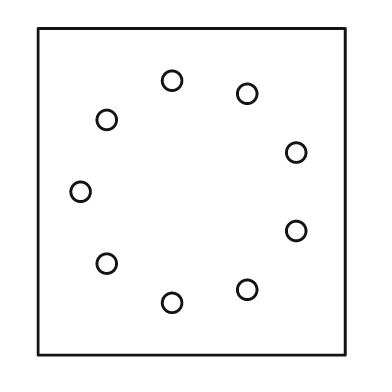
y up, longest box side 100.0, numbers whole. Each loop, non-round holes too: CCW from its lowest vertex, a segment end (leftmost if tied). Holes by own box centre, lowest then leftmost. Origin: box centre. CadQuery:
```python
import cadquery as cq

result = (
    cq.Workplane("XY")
    .moveTo(-47.0, -50.0)
    .lineTo(47.0, -50.0)
    .lineTo(47.0, 50.0)
    .lineTo(-47.0, 50.0)
    .close()
    .moveTo(-6.0, -34.0)
    .circle(3.0)
    .moveTo(17.0, -30.0)
    .circle(3.0)
    .moveTo(-26.0, -22.0)
    .circle(3.0)
    .moveTo(32.0, -12.0)
    .circle(3.0)
    .moveTo(-34.0, 0.0)
    .circle(3.0)
    .moveTo(32.0, 12.0)
    .circle(3.0)
    .moveTo(-26.0, 22.0)
    .circle(3.0)
    .moveTo(17.0, 30.0)
    .circle(3.0)
    .moveTo(-6.0, 34.0)
    .circle(3.0)
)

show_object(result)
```